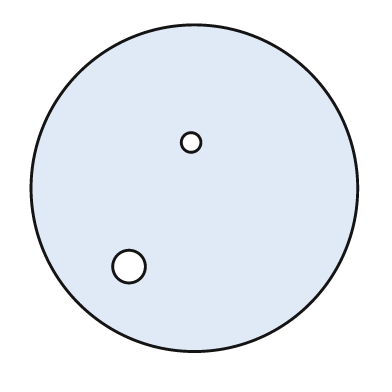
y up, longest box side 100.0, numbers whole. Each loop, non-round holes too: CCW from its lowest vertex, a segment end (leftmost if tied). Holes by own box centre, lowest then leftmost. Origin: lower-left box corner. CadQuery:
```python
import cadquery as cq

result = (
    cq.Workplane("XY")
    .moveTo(50.0, 50.0)
    .circle(50.0)
    .moveTo(30.0, 26.0)
    .circle(5.0)
    .moveTo(49.0, 64.0)
    .circle(3.0)
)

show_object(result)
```